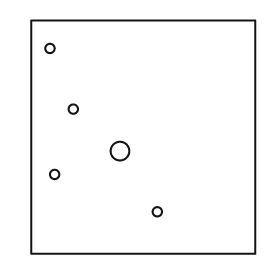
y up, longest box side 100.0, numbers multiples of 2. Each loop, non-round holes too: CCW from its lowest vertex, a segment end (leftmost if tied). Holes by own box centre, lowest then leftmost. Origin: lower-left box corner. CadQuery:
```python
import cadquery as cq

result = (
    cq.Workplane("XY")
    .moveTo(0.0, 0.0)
    .lineTo(96.0, 0.0)
    .lineTo(96.0, 100.0)
    .lineTo(0.0, 100.0)
    .close()
    .moveTo(54.0, 18.0)
    .circle(2.0)
    .moveTo(10.0, 34.0)
    .circle(2.0)
    .moveTo(38.0, 44.0)
    .circle(4.0)
    .moveTo(18.0, 62.0)
    .circle(2.0)
    .moveTo(8.0, 88.0)
    .circle(2.0)
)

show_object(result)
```